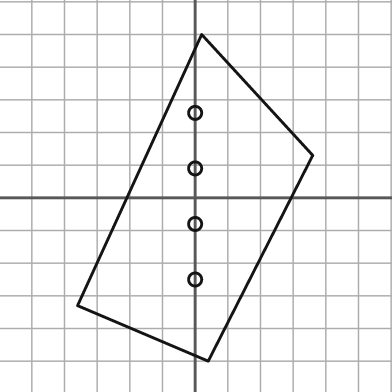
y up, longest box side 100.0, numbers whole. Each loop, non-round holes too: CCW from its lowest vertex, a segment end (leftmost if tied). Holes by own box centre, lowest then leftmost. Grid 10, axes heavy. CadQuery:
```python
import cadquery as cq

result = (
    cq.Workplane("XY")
    .moveTo(4.0, -50.0)
    .lineTo(36.0, 13.0)
    .lineTo(2.0, 50.0)
    .lineTo(-36.0, -33.0)
    .close()
    .moveTo(0.0, -25.0)
    .circle(2.0)
    .moveTo(0.0, -8.0)
    .circle(2.0)
    .moveTo(0.0, 9.0)
    .circle(2.0)
    .moveTo(0.0, 26.0)
    .circle(2.0)
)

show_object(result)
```